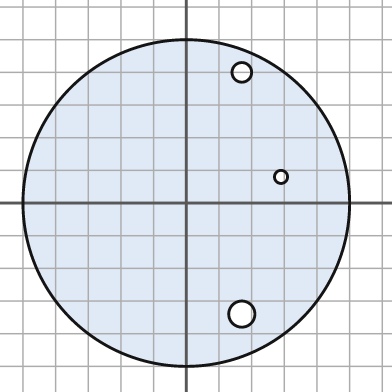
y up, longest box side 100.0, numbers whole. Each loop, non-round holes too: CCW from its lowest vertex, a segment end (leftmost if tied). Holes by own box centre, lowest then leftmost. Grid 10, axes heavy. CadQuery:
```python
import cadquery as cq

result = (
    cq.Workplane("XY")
    .moveTo(0.0, 0.0)
    .circle(50.0)
    .moveTo(17.0, -34.0)
    .circle(4.0)
    .moveTo(29.0, 8.0)
    .circle(2.0)
    .moveTo(17.0, 40.0)
    .circle(3.0)
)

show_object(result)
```